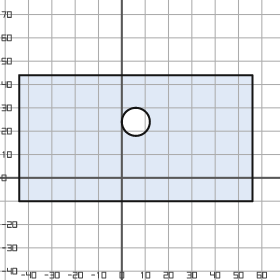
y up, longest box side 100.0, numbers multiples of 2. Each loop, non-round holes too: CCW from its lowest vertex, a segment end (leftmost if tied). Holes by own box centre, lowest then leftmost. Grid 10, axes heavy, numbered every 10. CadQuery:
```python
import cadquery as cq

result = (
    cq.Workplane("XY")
    .moveTo(-44.0, -10.0)
    .lineTo(56.0, -10.0)
    .lineTo(56.0, 44.0)
    .lineTo(-44.0, 44.0)
    .close()
    .moveTo(6.0, 24.0)
    .circle(6.0)
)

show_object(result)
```